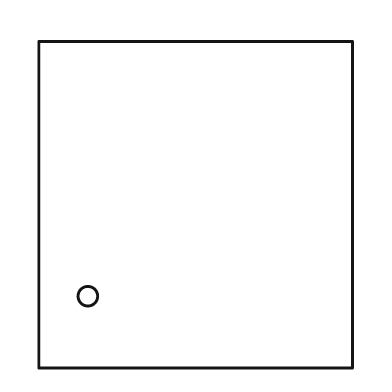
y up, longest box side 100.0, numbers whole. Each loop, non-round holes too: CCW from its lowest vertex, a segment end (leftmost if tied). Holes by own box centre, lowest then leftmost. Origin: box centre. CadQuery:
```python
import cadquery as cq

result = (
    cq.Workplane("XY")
    .moveTo(-48.0, -50.0)
    .lineTo(48.0, -50.0)
    .lineTo(48.0, 50.0)
    .lineTo(-48.0, 50.0)
    .close()
    .moveTo(-33.0, -28.0)
    .circle(3.0)
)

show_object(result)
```